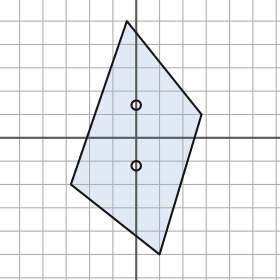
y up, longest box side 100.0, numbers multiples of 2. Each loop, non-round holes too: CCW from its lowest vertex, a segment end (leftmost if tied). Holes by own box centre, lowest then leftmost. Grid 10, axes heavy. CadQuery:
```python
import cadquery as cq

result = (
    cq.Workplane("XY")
    .moveTo(10.0, -50.0)
    .lineTo(28.0, 10.0)
    .lineTo(-4.0, 50.0)
    .lineTo(-28.0, -20.0)
    .close()
    .moveTo(0.0, -12.0)
    .circle(2.0)
    .moveTo(0.0, 14.0)
    .circle(2.0)
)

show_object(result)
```